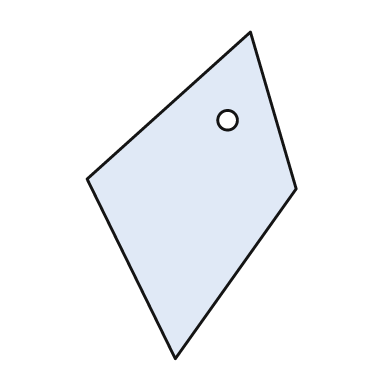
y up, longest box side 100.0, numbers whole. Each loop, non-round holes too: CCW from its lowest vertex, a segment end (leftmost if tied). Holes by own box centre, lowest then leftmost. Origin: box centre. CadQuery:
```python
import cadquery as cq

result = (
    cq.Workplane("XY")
    .moveTo(-5.0, -50.0)
    .lineTo(32.0, 2.0)
    .lineTo(18.0, 50.0)
    .lineTo(-32.0, 5.0)
    .close()
    .moveTo(11.0, 23.0)
    .circle(3.0)
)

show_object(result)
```